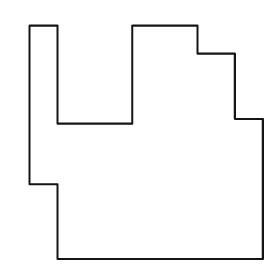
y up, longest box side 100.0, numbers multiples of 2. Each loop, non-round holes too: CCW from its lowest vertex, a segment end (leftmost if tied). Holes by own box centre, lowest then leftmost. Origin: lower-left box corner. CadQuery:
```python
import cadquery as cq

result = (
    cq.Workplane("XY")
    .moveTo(12.0, 0.0)
    .lineTo(100.0, 0.0)
    .lineTo(100.0, 60.0)
    .lineTo(88.0, 60.0)
    .lineTo(88.0, 88.0)
    .lineTo(72.0, 88.0)
    .lineTo(72.0, 100.0)
    .lineTo(44.0, 100.0)
    .lineTo(44.0, 58.0)
    .lineTo(12.0, 58.0)
    .lineTo(12.0, 100.0)
    .lineTo(0.0, 100.0)
    .lineTo(0.0, 32.0)
    .lineTo(12.0, 32.0)
    .close()
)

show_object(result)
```